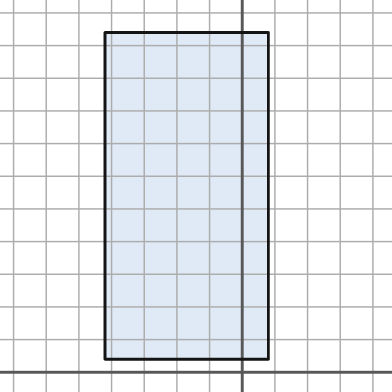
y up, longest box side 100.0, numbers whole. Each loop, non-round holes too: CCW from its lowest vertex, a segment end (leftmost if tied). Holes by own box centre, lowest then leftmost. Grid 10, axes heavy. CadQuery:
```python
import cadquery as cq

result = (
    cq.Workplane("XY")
    .moveTo(-42.0, 4.0)
    .lineTo(8.0, 4.0)
    .lineTo(8.0, 104.0)
    .lineTo(-42.0, 104.0)
    .close()
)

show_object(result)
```